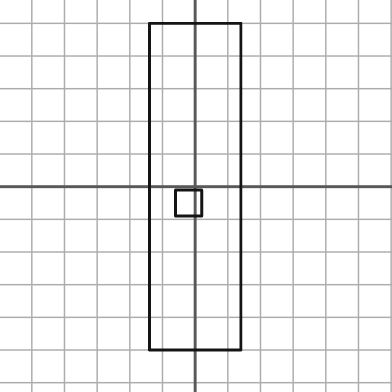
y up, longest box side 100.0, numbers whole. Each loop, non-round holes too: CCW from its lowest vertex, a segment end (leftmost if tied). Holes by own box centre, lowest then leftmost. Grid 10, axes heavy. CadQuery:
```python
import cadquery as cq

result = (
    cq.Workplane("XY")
    .moveTo(-14.0, -50.0)
    .lineTo(14.0, -50.0)
    .lineTo(14.0, 50.0)
    .lineTo(-14.0, 50.0)
    .close()
    .moveTo(-6.0, -9.0)
    .lineTo(2.0, -9.0)
    .lineTo(2.0, -1.0)
    .lineTo(-6.0, -1.0)
    .close()
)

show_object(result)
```